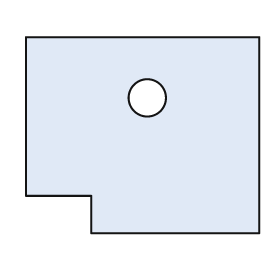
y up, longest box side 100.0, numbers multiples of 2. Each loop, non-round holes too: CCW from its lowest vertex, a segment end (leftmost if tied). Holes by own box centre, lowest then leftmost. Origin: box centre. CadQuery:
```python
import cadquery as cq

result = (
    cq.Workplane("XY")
    .moveTo(-22.0, -42.0)
    .lineTo(50.0, -42.0)
    .lineTo(50.0, 42.0)
    .lineTo(-50.0, 42.0)
    .lineTo(-50.0, -26.0)
    .lineTo(-22.0, -26.0)
    .close()
    .moveTo(2.0, 16.0)
    .circle(8.0)
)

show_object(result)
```